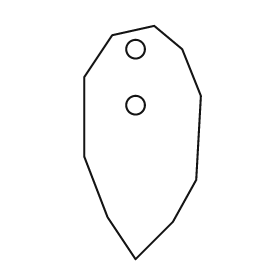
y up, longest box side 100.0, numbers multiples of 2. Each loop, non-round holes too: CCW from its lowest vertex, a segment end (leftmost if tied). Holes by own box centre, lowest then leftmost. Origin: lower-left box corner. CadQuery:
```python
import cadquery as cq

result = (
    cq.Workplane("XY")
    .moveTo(22.0, 0.0)
    .lineTo(38.0, 16.0)
    .lineTo(48.0, 34.0)
    .lineTo(50.0, 70.0)
    .lineTo(42.0, 90.0)
    .lineTo(30.0, 100.0)
    .lineTo(12.0, 96.0)
    .lineTo(0.0, 78.0)
    .lineTo(0.0, 44.0)
    .lineTo(10.0, 18.0)
    .close()
    .moveTo(22.0, 66.0)
    .circle(4.0)
    .moveTo(22.0, 90.0)
    .circle(4.0)
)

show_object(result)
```